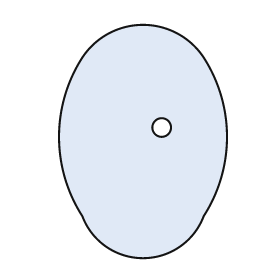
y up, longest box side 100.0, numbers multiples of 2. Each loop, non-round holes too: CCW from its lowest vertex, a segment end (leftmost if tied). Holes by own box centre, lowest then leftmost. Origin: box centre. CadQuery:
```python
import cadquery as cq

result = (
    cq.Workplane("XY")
    .moveTo(-26.0, -32.0)
    .threePointArc((0.0, -50.0), (26.0, -32.0))
    .threePointArc((36.0, 2.0), (26.0, 36.0))
    .threePointArc((0.0, 50.0), (-26.0, 36.0))
    .threePointArc((-36.0, 2.0), (-26.0, -32.0))
    .close()
    .moveTo(8.0, 6.0)
    .circle(4.0)
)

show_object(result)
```